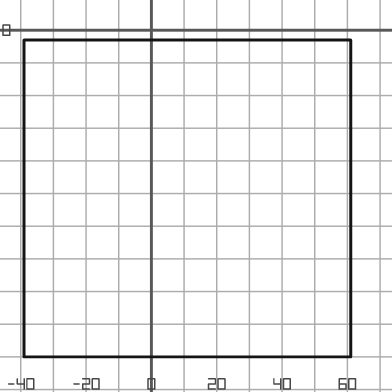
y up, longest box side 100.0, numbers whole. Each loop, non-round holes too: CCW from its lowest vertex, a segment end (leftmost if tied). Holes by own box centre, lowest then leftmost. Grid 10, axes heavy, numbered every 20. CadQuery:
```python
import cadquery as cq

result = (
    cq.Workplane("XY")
    .moveTo(-39.0, -100.0)
    .lineTo(61.0, -100.0)
    .lineTo(61.0, -3.0)
    .lineTo(-39.0, -3.0)
    .close()
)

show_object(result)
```